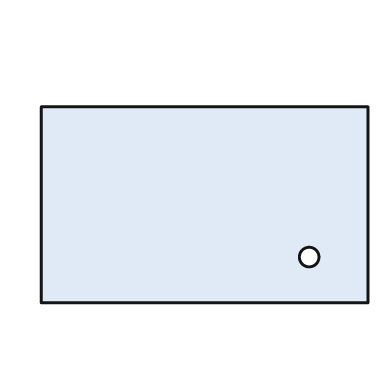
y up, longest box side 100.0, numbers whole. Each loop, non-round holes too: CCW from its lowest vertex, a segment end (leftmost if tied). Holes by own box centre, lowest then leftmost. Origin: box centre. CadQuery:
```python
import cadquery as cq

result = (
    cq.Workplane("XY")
    .moveTo(-50.0, -30.0)
    .lineTo(50.0, -30.0)
    .lineTo(50.0, 30.0)
    .lineTo(-50.0, 30.0)
    .close()
    .moveTo(32.0, -16.0)
    .circle(3.0)
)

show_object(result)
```